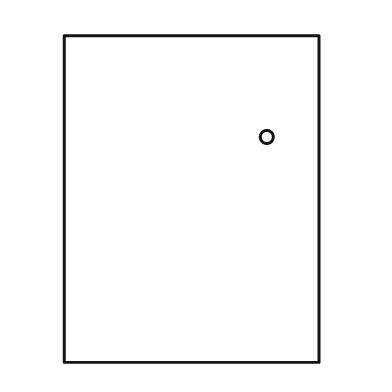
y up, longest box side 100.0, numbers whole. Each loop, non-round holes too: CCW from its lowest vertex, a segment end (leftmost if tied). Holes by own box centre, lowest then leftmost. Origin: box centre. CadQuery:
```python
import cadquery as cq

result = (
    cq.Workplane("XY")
    .moveTo(-39.0, -50.0)
    .lineTo(39.0, -50.0)
    .lineTo(39.0, 50.0)
    .lineTo(-39.0, 50.0)
    .close()
    .moveTo(23.0, 19.0)
    .circle(2.0)
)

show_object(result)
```